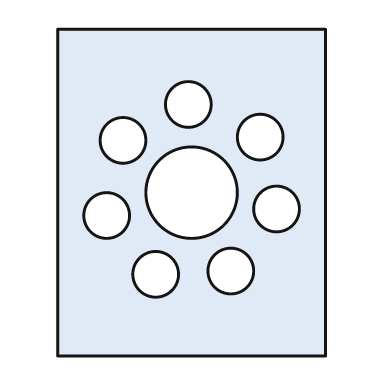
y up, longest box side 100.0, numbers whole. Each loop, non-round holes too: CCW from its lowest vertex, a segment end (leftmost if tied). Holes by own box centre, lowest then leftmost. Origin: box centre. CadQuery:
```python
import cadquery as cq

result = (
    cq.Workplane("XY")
    .moveTo(-41.0, -50.0)
    .lineTo(41.0, -50.0)
    .lineTo(41.0, 50.0)
    .lineTo(-41.0, 50.0)
    .close()
    .moveTo(-11.0, -25.0)
    .circle(7.0)
    .moveTo(12.0, -24.0)
    .circle(7.0)
    .moveTo(-26.0, -7.0)
    .circle(7.0)
    .moveTo(26.0, -5.0)
    .circle(7.0)
    .moveTo(0.0, 0.0)
    .circle(14.0)
    .moveTo(-21.0, 16.0)
    .circle(7.0)
    .moveTo(21.0, 17.0)
    .circle(7.0)
    .moveTo(-1.0, 27.0)
    .circle(7.0)
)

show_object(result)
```